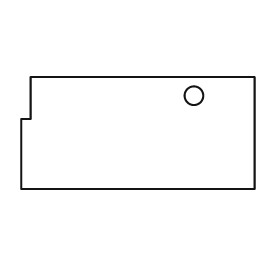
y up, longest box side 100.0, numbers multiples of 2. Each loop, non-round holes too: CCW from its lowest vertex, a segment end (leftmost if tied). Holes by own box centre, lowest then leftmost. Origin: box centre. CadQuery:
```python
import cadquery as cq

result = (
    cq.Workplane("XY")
    .moveTo(-50.0, -24.0)
    .lineTo(50.0, -24.0)
    .lineTo(50.0, 24.0)
    .lineTo(-46.0, 24.0)
    .lineTo(-46.0, 6.0)
    .lineTo(-50.0, 6.0)
    .close()
    .moveTo(24.0, 16.0)
    .circle(4.0)
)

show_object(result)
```